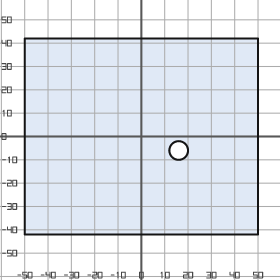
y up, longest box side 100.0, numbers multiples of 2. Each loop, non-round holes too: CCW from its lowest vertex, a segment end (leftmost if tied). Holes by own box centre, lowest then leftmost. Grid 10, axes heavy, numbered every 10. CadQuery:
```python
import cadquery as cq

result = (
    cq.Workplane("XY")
    .moveTo(-50.0, -42.0)
    .lineTo(50.0, -42.0)
    .lineTo(50.0, 42.0)
    .lineTo(-50.0, 42.0)
    .close()
    .moveTo(16.0, -6.0)
    .circle(4.0)
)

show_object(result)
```